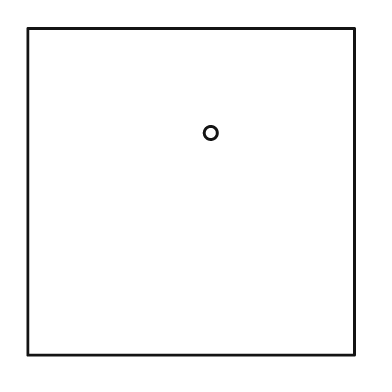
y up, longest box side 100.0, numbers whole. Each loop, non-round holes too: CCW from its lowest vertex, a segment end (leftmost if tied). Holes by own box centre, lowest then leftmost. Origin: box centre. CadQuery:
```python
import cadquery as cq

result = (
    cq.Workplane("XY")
    .moveTo(-50.0, -50.0)
    .lineTo(50.0, -50.0)
    .lineTo(50.0, 50.0)
    .lineTo(-50.0, 50.0)
    .close()
    .moveTo(6.0, 18.0)
    .circle(2.0)
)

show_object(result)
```